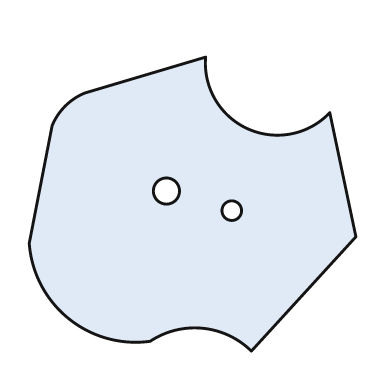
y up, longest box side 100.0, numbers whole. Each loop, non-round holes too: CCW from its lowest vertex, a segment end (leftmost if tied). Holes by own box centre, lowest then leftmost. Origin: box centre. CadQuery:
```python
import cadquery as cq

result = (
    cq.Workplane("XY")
    .moveTo(18.0, -45.0)
    .lineTo(50.0, -10.0)
    .lineTo(42.0, 28.0)
    .threePointArc((17.0, 23.0), (4.0, 45.0))
    .lineTo(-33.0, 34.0)
    .threePointArc((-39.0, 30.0), (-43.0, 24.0))
    .lineTo(-50.0, -12.0)
    .threePointArc((-38.0, -35.0), (-13.0, -42.0))
    .threePointArc((3.0, -38.0), (18.0, -45.0))
    .close()
    .moveTo(12.0, -2.0)
    .circle(3.0)
    .moveTo(-8.0, 4.0)
    .circle(4.0)
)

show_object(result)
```